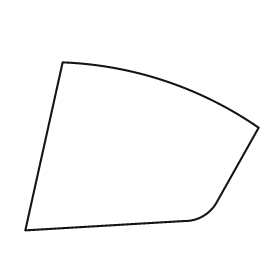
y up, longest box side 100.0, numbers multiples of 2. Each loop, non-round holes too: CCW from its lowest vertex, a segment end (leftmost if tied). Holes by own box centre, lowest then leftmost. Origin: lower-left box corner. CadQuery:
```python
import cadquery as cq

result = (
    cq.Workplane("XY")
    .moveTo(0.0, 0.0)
    .lineTo(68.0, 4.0)
    .threePointArc((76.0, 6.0), (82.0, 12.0))
    .lineTo(100.0, 44.0)
    .threePointArc((60.0, 64.0), (16.0, 72.0))
    .close()
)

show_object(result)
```